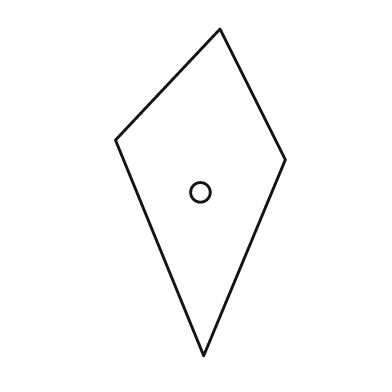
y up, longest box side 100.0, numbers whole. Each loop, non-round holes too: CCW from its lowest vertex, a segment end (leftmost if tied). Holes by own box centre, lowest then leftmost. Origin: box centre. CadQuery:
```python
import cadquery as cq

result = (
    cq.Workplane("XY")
    .moveTo(1.0, -50.0)
    .lineTo(26.0, 10.0)
    .lineTo(6.0, 50.0)
    .lineTo(-26.0, 16.0)
    .close()
    .moveTo(0.0, 0.0)
    .circle(3.0)
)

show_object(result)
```